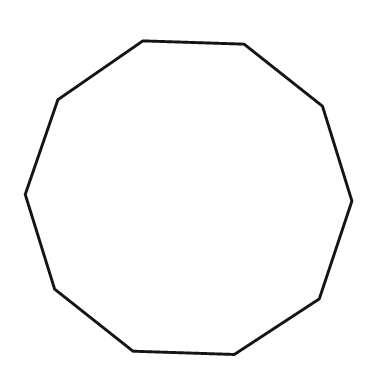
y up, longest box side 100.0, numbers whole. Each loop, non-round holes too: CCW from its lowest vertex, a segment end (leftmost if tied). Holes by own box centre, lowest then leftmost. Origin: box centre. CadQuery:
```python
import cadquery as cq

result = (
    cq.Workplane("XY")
    .moveTo(14.0, -48.0)
    .lineTo(40.0, -31.0)
    .lineTo(50.0, -1.0)
    .lineTo(41.0, 28.0)
    .lineTo(17.0, 47.0)
    .lineTo(-14.0, 48.0)
    .lineTo(-40.0, 30.0)
    .lineTo(-50.0, 1.0)
    .lineTo(-41.0, -28.0)
    .lineTo(-17.0, -47.0)
    .close()
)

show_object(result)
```